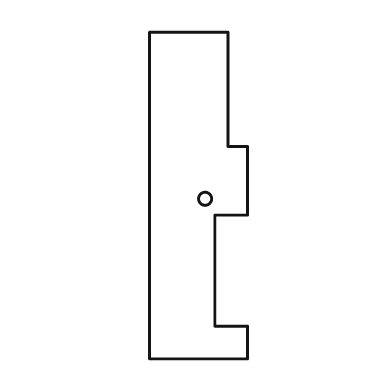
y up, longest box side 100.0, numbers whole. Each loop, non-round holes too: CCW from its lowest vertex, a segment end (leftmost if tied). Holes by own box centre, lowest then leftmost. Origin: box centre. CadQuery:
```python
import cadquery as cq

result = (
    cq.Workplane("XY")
    .moveTo(-15.0, -50.0)
    .lineTo(15.0, -50.0)
    .lineTo(15.0, -40.0)
    .lineTo(5.0, -40.0)
    .lineTo(5.0, -6.0)
    .lineTo(15.0, -6.0)
    .lineTo(15.0, 15.0)
    .lineTo(9.0, 15.0)
    .lineTo(9.0, 50.0)
    .lineTo(-15.0, 50.0)
    .close()
    .moveTo(2.0, -1.0)
    .circle(2.0)
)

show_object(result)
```